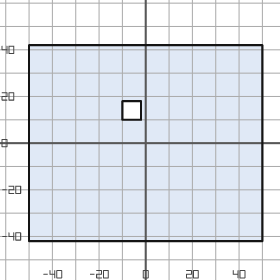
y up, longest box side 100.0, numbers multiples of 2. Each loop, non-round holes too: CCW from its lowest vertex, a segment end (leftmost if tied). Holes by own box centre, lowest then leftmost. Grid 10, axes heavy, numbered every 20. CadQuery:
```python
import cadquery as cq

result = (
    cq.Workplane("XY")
    .moveTo(-50.0, -42.0)
    .lineTo(50.0, -42.0)
    .lineTo(50.0, 42.0)
    .lineTo(-50.0, 42.0)
    .close()
    .moveTo(-10.0, 10.0)
    .lineTo(-2.0, 10.0)
    .lineTo(-2.0, 18.0)
    .lineTo(-10.0, 18.0)
    .close()
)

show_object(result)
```